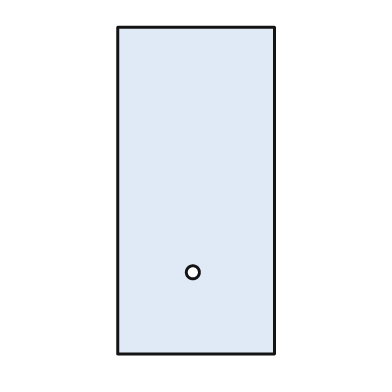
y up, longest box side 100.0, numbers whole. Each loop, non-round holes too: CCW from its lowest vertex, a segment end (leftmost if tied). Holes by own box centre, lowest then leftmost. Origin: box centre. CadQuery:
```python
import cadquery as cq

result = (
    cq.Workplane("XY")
    .moveTo(-24.0, -50.0)
    .lineTo(24.0, -50.0)
    .lineTo(24.0, 50.0)
    .lineTo(-24.0, 50.0)
    .close()
    .moveTo(-1.0, -25.0)
    .circle(2.0)
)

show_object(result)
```